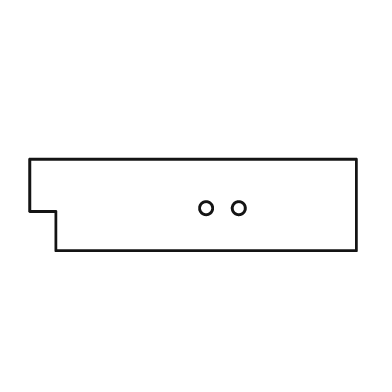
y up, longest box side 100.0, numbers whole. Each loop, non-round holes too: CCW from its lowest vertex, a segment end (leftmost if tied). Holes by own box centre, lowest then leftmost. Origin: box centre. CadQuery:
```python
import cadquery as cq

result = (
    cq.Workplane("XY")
    .moveTo(-42.0, -14.0)
    .lineTo(50.0, -14.0)
    .lineTo(50.0, 14.0)
    .lineTo(-50.0, 14.0)
    .lineTo(-50.0, -2.0)
    .lineTo(-42.0, -2.0)
    .close()
    .moveTo(4.0, -1.0)
    .circle(2.0)
    .moveTo(14.0, -1.0)
    .circle(2.0)
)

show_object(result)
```